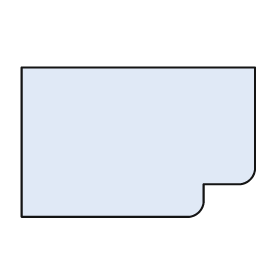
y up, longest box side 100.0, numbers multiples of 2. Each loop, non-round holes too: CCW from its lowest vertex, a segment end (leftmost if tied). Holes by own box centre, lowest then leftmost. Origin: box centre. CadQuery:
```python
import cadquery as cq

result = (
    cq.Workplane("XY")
    .moveTo(-50.0, -32.0)
    .lineTo(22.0, -32.0)
    .threePointArc((26.0, -30.0), (28.0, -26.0))
    .lineTo(28.0, -18.0)
    .lineTo(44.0, -18.0)
    .threePointArc((48.0, -16.0), (50.0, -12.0))
    .lineTo(50.0, 32.0)
    .lineTo(-50.0, 32.0)
    .close()
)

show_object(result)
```